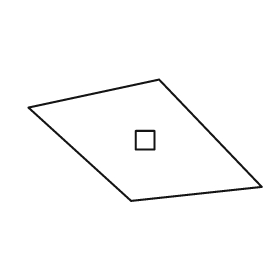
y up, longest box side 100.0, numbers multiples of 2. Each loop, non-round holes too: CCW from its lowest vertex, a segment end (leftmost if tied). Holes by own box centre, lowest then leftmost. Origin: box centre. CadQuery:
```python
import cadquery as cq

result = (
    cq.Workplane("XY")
    .moveTo(-6.0, -26.0)
    .lineTo(50.0, -20.0)
    .lineTo(6.0, 26.0)
    .lineTo(-50.0, 14.0)
    .close()
    .moveTo(-4.0, -4.0)
    .lineTo(4.0, -4.0)
    .lineTo(4.0, 4.0)
    .lineTo(-4.0, 4.0)
    .close()
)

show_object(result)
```